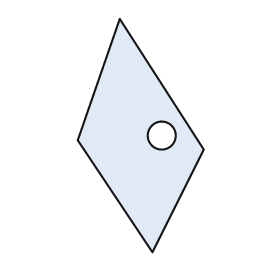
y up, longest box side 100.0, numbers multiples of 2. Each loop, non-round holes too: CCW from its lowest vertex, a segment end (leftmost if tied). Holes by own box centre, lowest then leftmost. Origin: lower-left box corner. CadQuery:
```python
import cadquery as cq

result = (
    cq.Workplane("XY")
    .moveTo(32.0, 0.0)
    .lineTo(54.0, 44.0)
    .lineTo(18.0, 100.0)
    .lineTo(0.0, 48.0)
    .close()
    .moveTo(36.0, 50.0)
    .circle(6.0)
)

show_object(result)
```